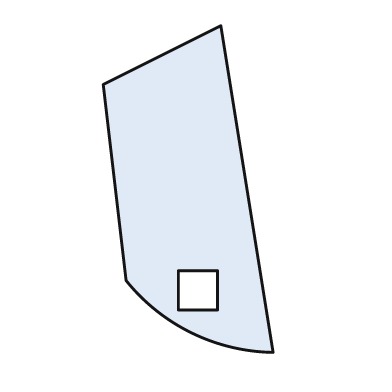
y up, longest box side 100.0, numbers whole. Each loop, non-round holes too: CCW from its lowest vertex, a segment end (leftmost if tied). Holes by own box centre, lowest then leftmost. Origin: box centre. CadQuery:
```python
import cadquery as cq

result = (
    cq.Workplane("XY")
    .moveTo(26.0, -50.0)
    .lineTo(10.0, 50.0)
    .lineTo(-26.0, 32.0)
    .lineTo(-19.0, -28.0)
    .threePointArc((1.0, -44.0), (26.0, -50.0))
    .close()
    .moveTo(-3.0, -37.0)
    .lineTo(9.0, -37.0)
    .lineTo(9.0, -25.0)
    .lineTo(-3.0, -25.0)
    .close()
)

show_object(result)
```